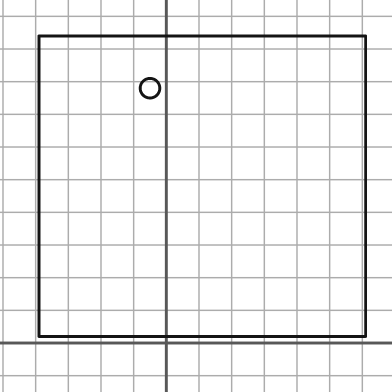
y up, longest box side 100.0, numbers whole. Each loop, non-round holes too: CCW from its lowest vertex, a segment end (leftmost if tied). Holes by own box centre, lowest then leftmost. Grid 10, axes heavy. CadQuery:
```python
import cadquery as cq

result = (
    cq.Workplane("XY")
    .moveTo(-39.0, 2.0)
    .lineTo(61.0, 2.0)
    .lineTo(61.0, 94.0)
    .lineTo(-39.0, 94.0)
    .close()
    .moveTo(-5.0, 78.0)
    .circle(3.0)
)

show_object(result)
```